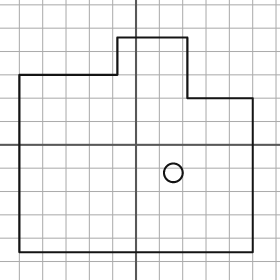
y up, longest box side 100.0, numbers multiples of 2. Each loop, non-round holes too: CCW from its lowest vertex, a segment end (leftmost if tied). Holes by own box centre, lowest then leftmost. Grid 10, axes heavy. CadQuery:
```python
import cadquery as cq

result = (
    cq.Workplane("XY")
    .moveTo(-50.0, -46.0)
    .lineTo(50.0, -46.0)
    .lineTo(50.0, 20.0)
    .lineTo(22.0, 20.0)
    .lineTo(22.0, 46.0)
    .lineTo(-8.0, 46.0)
    .lineTo(-8.0, 30.0)
    .lineTo(-50.0, 30.0)
    .close()
    .moveTo(16.0, -12.0)
    .circle(4.0)
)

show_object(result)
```